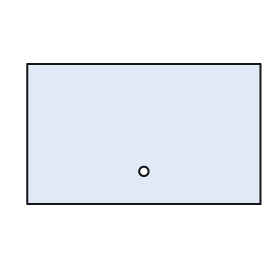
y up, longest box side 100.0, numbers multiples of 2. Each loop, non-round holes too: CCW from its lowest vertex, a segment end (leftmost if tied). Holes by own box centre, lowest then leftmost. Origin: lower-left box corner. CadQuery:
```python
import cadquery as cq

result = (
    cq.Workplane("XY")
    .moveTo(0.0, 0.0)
    .lineTo(100.0, 0.0)
    .lineTo(100.0, 60.0)
    .lineTo(0.0, 60.0)
    .close()
    .moveTo(50.0, 14.0)
    .circle(2.0)
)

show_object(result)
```